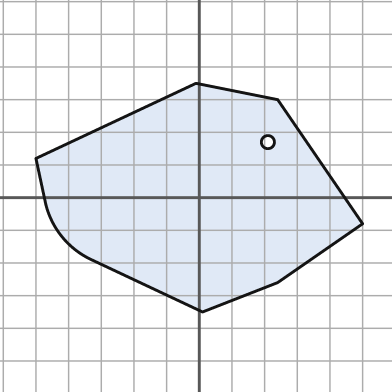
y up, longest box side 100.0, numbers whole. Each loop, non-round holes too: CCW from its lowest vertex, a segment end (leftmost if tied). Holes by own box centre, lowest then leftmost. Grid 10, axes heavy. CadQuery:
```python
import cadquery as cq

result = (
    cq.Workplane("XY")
    .moveTo(1.0, -35.0)
    .lineTo(24.0, -26.0)
    .lineTo(50.0, -8.0)
    .lineTo(24.0, 30.0)
    .lineTo(-1.0, 35.0)
    .lineTo(-50.0, 12.0)
    .lineTo(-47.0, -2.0)
    .threePointArc((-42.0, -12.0), (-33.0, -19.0))
    .close()
    .moveTo(21.0, 17.0)
    .circle(2.0)
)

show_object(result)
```